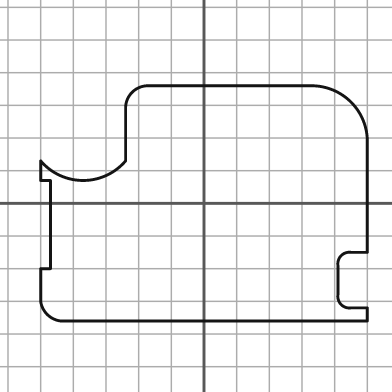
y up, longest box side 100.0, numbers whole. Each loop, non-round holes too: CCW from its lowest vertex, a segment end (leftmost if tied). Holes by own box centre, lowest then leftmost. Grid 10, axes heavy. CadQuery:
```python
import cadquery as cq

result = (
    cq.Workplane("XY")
    .moveTo(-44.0, -36.0)
    .lineTo(50.0, -36.0)
    .lineTo(50.0, -32.0)
    .lineTo(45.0, -32.0)
    .threePointArc((42.0, -31.0), (41.0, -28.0))
    .lineTo(41.0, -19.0)
    .threePointArc((42.0, -16.0), (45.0, -15.0))
    .lineTo(50.0, -15.0)
    .lineTo(50.0, 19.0)
    .threePointArc((45.0, 31.0), (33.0, 36.0))
    .lineTo(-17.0, 36.0)
    .threePointArc((-22.0, 34.0), (-24.0, 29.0))
    .lineTo(-24.0, 13.0)
    .threePointArc((-37.0, 7.0), (-50.0, 13.0))
    .lineTo(-50.0, 7.0)
    .lineTo(-47.0, 7.0)
    .lineTo(-47.0, -20.0)
    .lineTo(-50.0, -20.0)
    .lineTo(-50.0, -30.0)
    .threePointArc((-48.0, -34.0), (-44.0, -36.0))
    .close()
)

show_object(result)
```